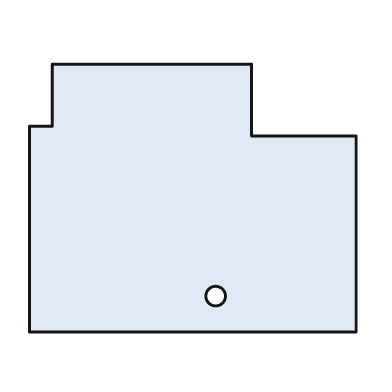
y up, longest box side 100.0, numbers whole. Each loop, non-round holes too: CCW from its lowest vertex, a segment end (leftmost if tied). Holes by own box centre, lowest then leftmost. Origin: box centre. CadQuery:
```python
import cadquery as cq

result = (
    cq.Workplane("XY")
    .moveTo(-50.0, -41.0)
    .lineTo(50.0, -41.0)
    .lineTo(50.0, 19.0)
    .lineTo(18.0, 19.0)
    .lineTo(18.0, 41.0)
    .lineTo(-43.0, 41.0)
    .lineTo(-43.0, 22.0)
    .lineTo(-50.0, 22.0)
    .close()
    .moveTo(7.0, -30.0)
    .circle(3.0)
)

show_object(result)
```